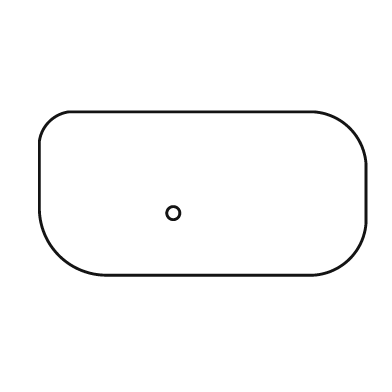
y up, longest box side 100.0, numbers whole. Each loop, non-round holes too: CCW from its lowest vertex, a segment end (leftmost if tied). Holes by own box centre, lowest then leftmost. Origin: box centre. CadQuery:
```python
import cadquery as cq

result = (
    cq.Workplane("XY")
    .moveTo(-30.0, -25.0)
    .lineTo(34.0, -25.0)
    .threePointArc((45.0, -20.0), (50.0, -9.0))
    .lineTo(50.0, 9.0)
    .threePointArc((45.0, 20.0), (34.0, 25.0))
    .lineTo(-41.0, 25.0)
    .threePointArc((-47.0, 22.0), (-50.0, 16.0))
    .lineTo(-50.0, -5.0)
    .threePointArc((-44.0, -19.0), (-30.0, -25.0))
    .close()
    .moveTo(-9.0, -6.0)
    .circle(2.0)
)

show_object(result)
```